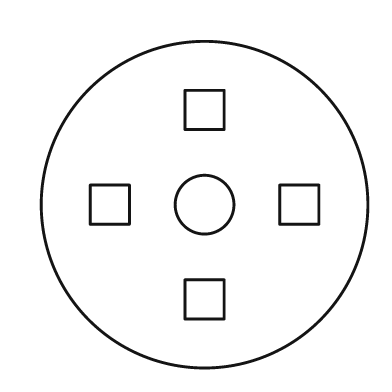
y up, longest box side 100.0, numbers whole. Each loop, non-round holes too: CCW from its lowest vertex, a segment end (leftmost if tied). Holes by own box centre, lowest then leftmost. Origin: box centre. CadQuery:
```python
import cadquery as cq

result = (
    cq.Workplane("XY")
    .moveTo(0.0, 0.0)
    .circle(50.0)
    .moveTo(-6.0, -35.0)
    .lineTo(6.0, -35.0)
    .lineTo(6.0, -23.0)
    .lineTo(-6.0, -23.0)
    .close()
    .moveTo(-35.0, -6.0)
    .lineTo(-23.0, -6.0)
    .lineTo(-23.0, 6.0)
    .lineTo(-35.0, 6.0)
    .close()
    .moveTo(0.0, 0.0)
    .circle(9.0)
    .moveTo(23.0, -6.0)
    .lineTo(35.0, -6.0)
    .lineTo(35.0, 6.0)
    .lineTo(23.0, 6.0)
    .close()
    .moveTo(-6.0, 23.0)
    .lineTo(6.0, 23.0)
    .lineTo(6.0, 35.0)
    .lineTo(-6.0, 35.0)
    .close()
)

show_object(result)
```